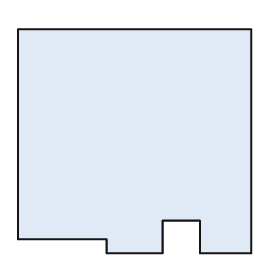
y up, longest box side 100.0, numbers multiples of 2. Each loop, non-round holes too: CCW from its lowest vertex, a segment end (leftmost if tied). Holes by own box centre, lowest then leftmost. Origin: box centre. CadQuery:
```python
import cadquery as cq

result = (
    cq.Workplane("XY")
    .moveTo(-12.0, -48.0)
    .lineTo(12.0, -48.0)
    .lineTo(12.0, -34.0)
    .lineTo(28.0, -34.0)
    .lineTo(28.0, -48.0)
    .lineTo(50.0, -48.0)
    .lineTo(50.0, 48.0)
    .lineTo(-50.0, 48.0)
    .lineTo(-50.0, -42.0)
    .lineTo(-12.0, -42.0)
    .close()
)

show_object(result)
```